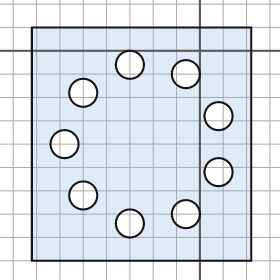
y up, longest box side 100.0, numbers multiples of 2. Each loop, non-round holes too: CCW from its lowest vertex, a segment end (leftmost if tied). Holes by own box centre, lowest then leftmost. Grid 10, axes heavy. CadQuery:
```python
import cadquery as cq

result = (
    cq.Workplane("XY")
    .moveTo(-72.0, -90.0)
    .lineTo(22.0, -90.0)
    .lineTo(22.0, 10.0)
    .lineTo(-72.0, 10.0)
    .close()
    .moveTo(-30.0, -74.0)
    .circle(6.0)
    .moveTo(-6.0, -70.0)
    .circle(6.0)
    .moveTo(-50.0, -62.0)
    .circle(6.0)
    .moveTo(8.0, -52.0)
    .circle(6.0)
    .moveTo(-58.0, -40.0)
    .circle(6.0)
    .moveTo(8.0, -28.0)
    .circle(6.0)
    .moveTo(-50.0, -18.0)
    .circle(6.0)
    .moveTo(-6.0, -10.0)
    .circle(6.0)
    .moveTo(-30.0, -6.0)
    .circle(6.0)
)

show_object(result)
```